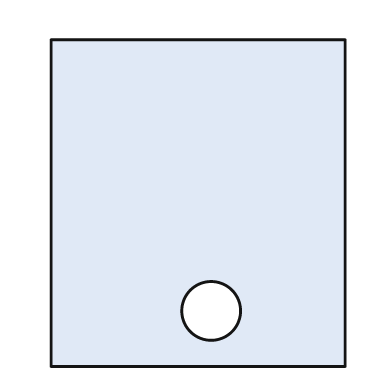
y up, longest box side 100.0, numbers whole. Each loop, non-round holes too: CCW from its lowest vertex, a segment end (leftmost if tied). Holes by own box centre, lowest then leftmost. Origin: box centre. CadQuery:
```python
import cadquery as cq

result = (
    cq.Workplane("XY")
    .moveTo(-45.0, -50.0)
    .lineTo(45.0, -50.0)
    .lineTo(45.0, 50.0)
    .lineTo(-45.0, 50.0)
    .close()
    .moveTo(4.0, -33.0)
    .circle(9.0)
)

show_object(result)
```